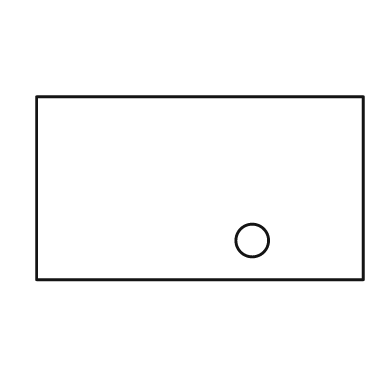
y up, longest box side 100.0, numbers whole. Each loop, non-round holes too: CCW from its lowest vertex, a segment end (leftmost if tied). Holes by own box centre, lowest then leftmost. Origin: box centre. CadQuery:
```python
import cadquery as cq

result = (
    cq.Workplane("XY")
    .moveTo(-50.0, -28.0)
    .lineTo(50.0, -28.0)
    .lineTo(50.0, 28.0)
    .lineTo(-50.0, 28.0)
    .close()
    .moveTo(16.0, -16.0)
    .circle(5.0)
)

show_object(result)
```